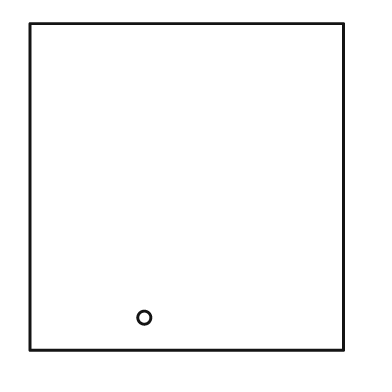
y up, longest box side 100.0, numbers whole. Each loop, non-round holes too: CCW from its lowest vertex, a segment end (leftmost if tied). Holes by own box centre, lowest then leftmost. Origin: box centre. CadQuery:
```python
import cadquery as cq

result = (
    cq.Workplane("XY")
    .moveTo(-48.0, -50.0)
    .lineTo(48.0, -50.0)
    .lineTo(48.0, 50.0)
    .lineTo(-48.0, 50.0)
    .close()
    .moveTo(-13.0, -40.0)
    .circle(2.0)
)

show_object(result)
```